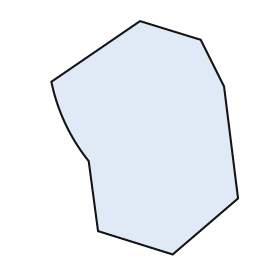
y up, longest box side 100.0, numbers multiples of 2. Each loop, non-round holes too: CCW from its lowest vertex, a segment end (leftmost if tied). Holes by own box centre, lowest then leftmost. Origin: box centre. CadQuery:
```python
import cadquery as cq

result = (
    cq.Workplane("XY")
    .moveTo(12.0, -50.0)
    .lineTo(40.0, -26.0)
    .lineTo(34.0, 22.0)
    .lineTo(24.0, 42.0)
    .lineTo(-2.0, 50.0)
    .lineTo(-40.0, 24.0)
    .threePointArc((-34.0, 6.0), (-24.0, -10.0))
    .lineTo(-20.0, -40.0)
    .close()
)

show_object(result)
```